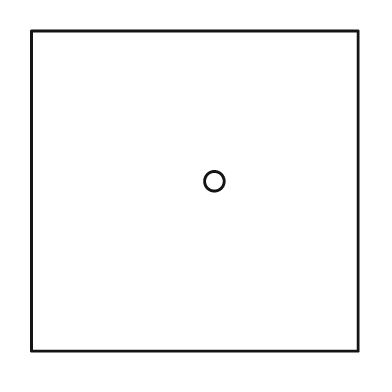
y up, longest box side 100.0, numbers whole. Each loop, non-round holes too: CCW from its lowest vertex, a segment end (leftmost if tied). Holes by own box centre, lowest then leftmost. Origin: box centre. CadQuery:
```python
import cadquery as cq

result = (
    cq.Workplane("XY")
    .moveTo(-50.0, -49.0)
    .lineTo(50.0, -49.0)
    .lineTo(50.0, 49.0)
    .lineTo(-50.0, 49.0)
    .close()
    .moveTo(6.0, 3.0)
    .circle(3.0)
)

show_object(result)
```